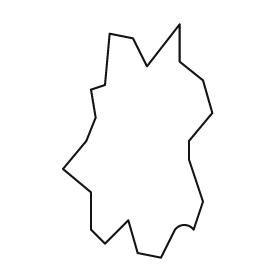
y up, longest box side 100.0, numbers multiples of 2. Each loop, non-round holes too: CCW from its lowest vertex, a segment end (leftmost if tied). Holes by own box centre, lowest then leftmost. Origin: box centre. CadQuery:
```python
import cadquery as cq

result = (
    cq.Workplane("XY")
    .moveTo(10.0, -50.0)
    .lineTo(16.0, -38.0)
    .threePointArc((20.0, -36.0), (24.0, -38.0))
    .lineTo(28.0, -26.0)
    .lineTo(22.0, -8.0)
    .lineTo(22.0, 0.0)
    .lineTo(32.0, 12.0)
    .lineTo(28.0, 26.0)
    .lineTo(18.0, 34.0)
    .lineTo(18.0, 50.0)
    .lineTo(4.0, 32.0)
    .lineTo(-2.0, 44.0)
    .lineTo(-12.0, 46.0)
    .lineTo(-14.0, 24.0)
    .lineTo(-20.0, 22.0)
    .lineTo(-18.0, 10.0)
    .lineTo(-22.0, 0.0)
    .lineTo(-32.0, -12.0)
    .lineTo(-20.0, -22.0)
    .lineTo(-20.0, -38.0)
    .lineTo(-14.0, -44.0)
    .lineTo(-4.0, -34.0)
    .lineTo(0.0, -48.0)
    .close()
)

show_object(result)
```